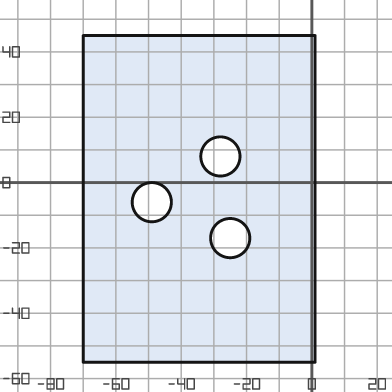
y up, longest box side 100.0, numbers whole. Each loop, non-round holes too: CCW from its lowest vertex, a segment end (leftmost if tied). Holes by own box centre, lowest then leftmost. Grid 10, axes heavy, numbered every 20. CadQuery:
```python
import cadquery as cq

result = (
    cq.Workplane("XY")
    .moveTo(-70.0, -55.0)
    .lineTo(1.0, -55.0)
    .lineTo(1.0, 45.0)
    .lineTo(-70.0, 45.0)
    .close()
    .moveTo(-25.0, -17.0)
    .circle(6.0)
    .moveTo(-49.0, -6.0)
    .circle(6.0)
    .moveTo(-28.0, 8.0)
    .circle(6.0)
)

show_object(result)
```